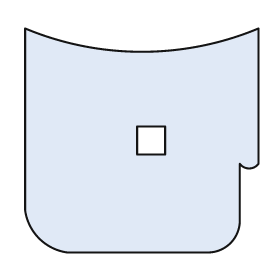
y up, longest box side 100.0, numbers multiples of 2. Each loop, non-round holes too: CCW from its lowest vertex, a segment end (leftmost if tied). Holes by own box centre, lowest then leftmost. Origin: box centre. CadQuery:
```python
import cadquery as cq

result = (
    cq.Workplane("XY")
    .moveTo(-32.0, -48.0)
    .lineTo(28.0, -48.0)
    .threePointArc((38.0, -44.0), (42.0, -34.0))
    .lineTo(42.0, -10.0)
    .threePointArc((46.0, -12.0), (50.0, -10.0))
    .lineTo(50.0, 48.0)
    .threePointArc((0.0, 38.0), (-50.0, 48.0))
    .lineTo(-50.0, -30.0)
    .threePointArc((-44.0, -42.0), (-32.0, -48.0))
    .close()
    .moveTo(-2.0, -6.0)
    .lineTo(10.0, -6.0)
    .lineTo(10.0, 6.0)
    .lineTo(-2.0, 6.0)
    .close()
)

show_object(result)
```